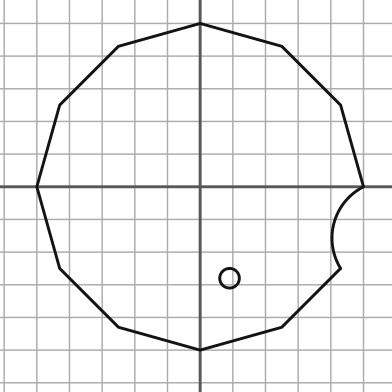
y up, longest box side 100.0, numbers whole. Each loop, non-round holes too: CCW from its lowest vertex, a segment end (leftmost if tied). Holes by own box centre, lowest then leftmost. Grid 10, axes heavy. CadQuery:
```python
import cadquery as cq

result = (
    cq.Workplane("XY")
    .moveTo(0.0, -50.0)
    .lineTo(25.0, -43.0)
    .lineTo(43.0, -25.0)
    .threePointArc((41.0, -11.0), (50.0, 0.0))
    .lineTo(43.0, 25.0)
    .lineTo(25.0, 43.0)
    .lineTo(0.0, 50.0)
    .lineTo(-25.0, 43.0)
    .lineTo(-43.0, 25.0)
    .lineTo(-50.0, 0.0)
    .lineTo(-43.0, -25.0)
    .lineTo(-25.0, -43.0)
    .close()
    .moveTo(9.0, -28.0)
    .circle(3.0)
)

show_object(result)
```